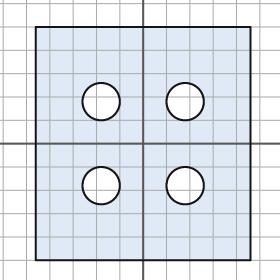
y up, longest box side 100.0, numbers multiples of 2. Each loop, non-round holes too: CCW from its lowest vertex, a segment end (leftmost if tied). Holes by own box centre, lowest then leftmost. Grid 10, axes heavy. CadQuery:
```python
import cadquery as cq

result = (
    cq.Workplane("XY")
    .moveTo(-46.0, -50.0)
    .lineTo(46.0, -50.0)
    .lineTo(46.0, 50.0)
    .lineTo(-46.0, 50.0)
    .close()
    .moveTo(-18.0, -18.0)
    .circle(8.0)
    .moveTo(18.0, -18.0)
    .circle(8.0)
    .moveTo(-18.0, 18.0)
    .circle(8.0)
    .moveTo(18.0, 18.0)
    .circle(8.0)
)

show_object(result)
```